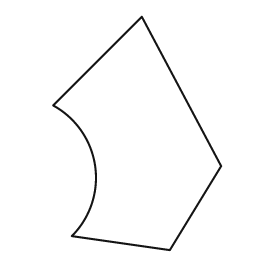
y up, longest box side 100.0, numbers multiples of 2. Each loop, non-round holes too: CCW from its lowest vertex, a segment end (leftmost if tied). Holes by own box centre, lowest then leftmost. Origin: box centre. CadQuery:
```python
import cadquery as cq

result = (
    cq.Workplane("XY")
    .moveTo(14.0, -50.0)
    .lineTo(36.0, -14.0)
    .lineTo(2.0, 50.0)
    .lineTo(-36.0, 12.0)
    .threePointArc((-18.0, -14.0), (-28.0, -44.0))
    .close()
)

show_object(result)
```